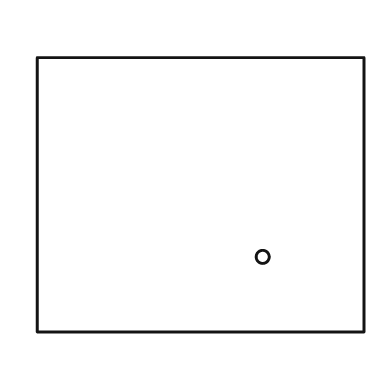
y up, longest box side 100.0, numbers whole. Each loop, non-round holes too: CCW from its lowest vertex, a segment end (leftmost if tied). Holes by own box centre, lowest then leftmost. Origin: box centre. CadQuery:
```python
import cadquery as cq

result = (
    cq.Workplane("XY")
    .moveTo(-50.0, -42.0)
    .lineTo(50.0, -42.0)
    .lineTo(50.0, 42.0)
    .lineTo(-50.0, 42.0)
    .close()
    .moveTo(19.0, -19.0)
    .circle(2.0)
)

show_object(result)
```